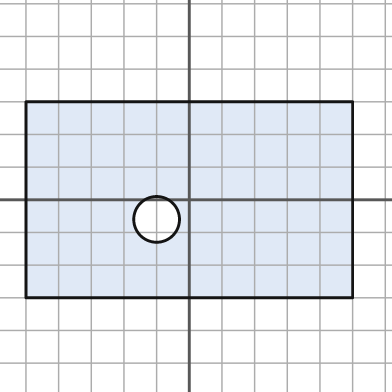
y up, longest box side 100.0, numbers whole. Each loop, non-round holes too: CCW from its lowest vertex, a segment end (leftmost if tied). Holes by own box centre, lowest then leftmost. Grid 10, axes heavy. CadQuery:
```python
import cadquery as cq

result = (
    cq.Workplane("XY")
    .moveTo(-50.0, -30.0)
    .lineTo(50.0, -30.0)
    .lineTo(50.0, 30.0)
    .lineTo(-50.0, 30.0)
    .close()
    .moveTo(-10.0, -6.0)
    .circle(7.0)
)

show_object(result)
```